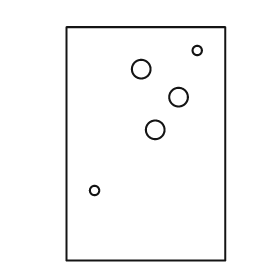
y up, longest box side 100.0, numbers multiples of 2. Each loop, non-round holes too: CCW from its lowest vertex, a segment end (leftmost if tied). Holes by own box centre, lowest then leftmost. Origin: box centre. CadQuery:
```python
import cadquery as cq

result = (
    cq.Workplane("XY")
    .moveTo(-34.0, -50.0)
    .lineTo(34.0, -50.0)
    .lineTo(34.0, 50.0)
    .lineTo(-34.0, 50.0)
    .close()
    .moveTo(-22.0, -20.0)
    .circle(2.0)
    .moveTo(4.0, 6.0)
    .circle(4.0)
    .moveTo(14.0, 20.0)
    .circle(4.0)
    .moveTo(-2.0, 32.0)
    .circle(4.0)
    .moveTo(22.0, 40.0)
    .circle(2.0)
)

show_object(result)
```